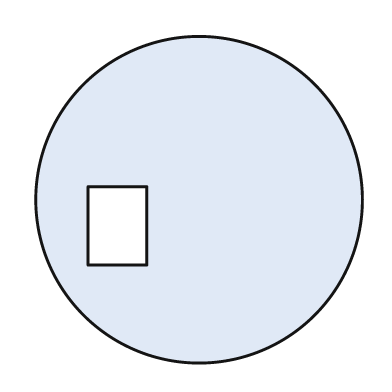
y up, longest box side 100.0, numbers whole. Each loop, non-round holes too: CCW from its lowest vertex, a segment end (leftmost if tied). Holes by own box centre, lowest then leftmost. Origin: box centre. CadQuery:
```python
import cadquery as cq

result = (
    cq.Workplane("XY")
    .moveTo(0.0, 0.0)
    .circle(50.0)
    .moveTo(-34.0, -20.0)
    .lineTo(-16.0, -20.0)
    .lineTo(-16.0, 4.0)
    .lineTo(-34.0, 4.0)
    .close()
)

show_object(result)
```